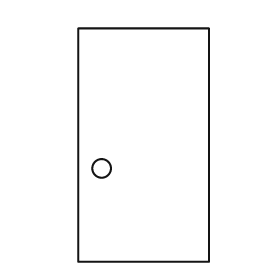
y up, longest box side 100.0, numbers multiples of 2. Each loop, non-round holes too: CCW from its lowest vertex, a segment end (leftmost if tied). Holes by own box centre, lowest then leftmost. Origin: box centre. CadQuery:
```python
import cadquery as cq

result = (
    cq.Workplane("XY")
    .moveTo(-28.0, -50.0)
    .lineTo(28.0, -50.0)
    .lineTo(28.0, 50.0)
    .lineTo(-28.0, 50.0)
    .close()
    .moveTo(-18.0, -10.0)
    .circle(4.0)
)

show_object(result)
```